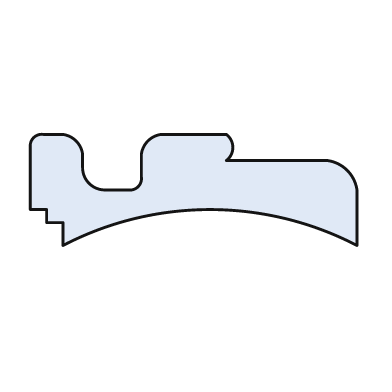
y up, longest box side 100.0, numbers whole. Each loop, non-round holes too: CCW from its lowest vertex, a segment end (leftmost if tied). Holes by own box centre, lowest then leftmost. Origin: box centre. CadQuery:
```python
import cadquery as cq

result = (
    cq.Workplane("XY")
    .moveTo(-40.0, -17.0)
    .threePointArc((5.0, -6.0), (50.0, -17.0))
    .lineTo(50.0, 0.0)
    .threePointArc((47.0, 6.0), (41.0, 9.0))
    .lineTo(10.0, 9.0)
    .threePointArc((12.0, 13.0), (10.0, 17.0))
    .lineTo(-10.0, 17.0)
    .threePointArc((-14.0, 15.0), (-16.0, 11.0))
    .lineTo(-16.0, 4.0)
    .threePointArc((-17.0, 1.0), (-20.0, 0.0))
    .lineTo(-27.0, 0.0)
    .threePointArc((-32.0, 2.0), (-34.0, 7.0))
    .lineTo(-34.0, 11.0)
    .threePointArc((-36.0, 15.0), (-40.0, 17.0))
    .lineTo(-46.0, 17.0)
    .threePointArc((-49.0, 16.0), (-50.0, 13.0))
    .lineTo(-50.0, -6.0)
    .lineTo(-45.0, -6.0)
    .lineTo(-45.0, -10.0)
    .lineTo(-40.0, -10.0)
    .close()
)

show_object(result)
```